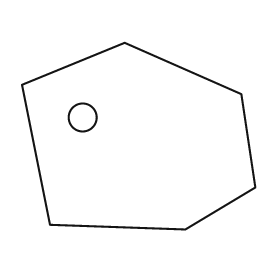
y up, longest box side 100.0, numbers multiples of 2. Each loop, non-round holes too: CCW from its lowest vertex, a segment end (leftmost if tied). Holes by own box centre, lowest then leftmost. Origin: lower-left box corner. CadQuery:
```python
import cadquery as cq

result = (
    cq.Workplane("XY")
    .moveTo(70.0, 0.0)
    .lineTo(100.0, 18.0)
    .lineTo(94.0, 58.0)
    .lineTo(44.0, 80.0)
    .lineTo(0.0, 62.0)
    .lineTo(12.0, 2.0)
    .close()
    .moveTo(26.0, 48.0)
    .circle(6.0)
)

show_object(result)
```